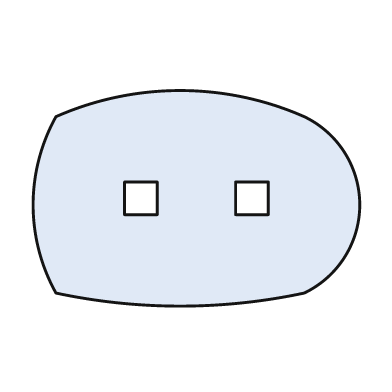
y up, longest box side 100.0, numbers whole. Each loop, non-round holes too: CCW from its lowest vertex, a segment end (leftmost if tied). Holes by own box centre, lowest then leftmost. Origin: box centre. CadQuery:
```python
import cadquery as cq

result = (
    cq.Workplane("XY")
    .moveTo(-43.0, -29.0)
    .threePointArc((-5.0, -33.0), (33.0, -29.0))
    .threePointArc((50.0, -2.0), (33.0, 25.0))
    .threePointArc((-5.0, 33.0), (-43.0, 25.0))
    .threePointArc((-50.0, -2.0), (-43.0, -29.0))
    .close()
    .moveTo(-22.0, -5.0)
    .lineTo(-12.0, -5.0)
    .lineTo(-12.0, 5.0)
    .lineTo(-22.0, 5.0)
    .close()
    .moveTo(12.0, -5.0)
    .lineTo(22.0, -5.0)
    .lineTo(22.0, 5.0)
    .lineTo(12.0, 5.0)
    .close()
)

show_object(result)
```